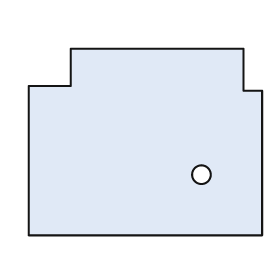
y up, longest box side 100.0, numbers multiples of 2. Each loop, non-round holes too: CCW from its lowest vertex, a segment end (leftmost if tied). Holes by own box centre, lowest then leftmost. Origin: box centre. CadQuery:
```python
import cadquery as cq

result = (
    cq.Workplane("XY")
    .moveTo(-50.0, -40.0)
    .lineTo(50.0, -40.0)
    .lineTo(50.0, 22.0)
    .lineTo(42.0, 22.0)
    .lineTo(42.0, 40.0)
    .lineTo(-32.0, 40.0)
    .lineTo(-32.0, 24.0)
    .lineTo(-50.0, 24.0)
    .close()
    .moveTo(24.0, -14.0)
    .circle(4.0)
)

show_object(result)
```